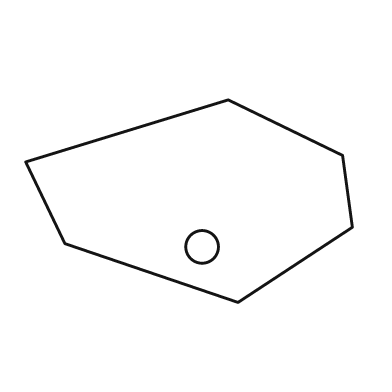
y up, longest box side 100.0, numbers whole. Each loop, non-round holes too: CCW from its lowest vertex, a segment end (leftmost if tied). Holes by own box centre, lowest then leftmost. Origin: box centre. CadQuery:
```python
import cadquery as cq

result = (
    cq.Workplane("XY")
    .moveTo(15.0, -31.0)
    .lineTo(50.0, -8.0)
    .lineTo(47.0, 14.0)
    .lineTo(12.0, 31.0)
    .lineTo(-50.0, 12.0)
    .lineTo(-38.0, -13.0)
    .close()
    .moveTo(4.0, -14.0)
    .circle(5.0)
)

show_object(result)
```